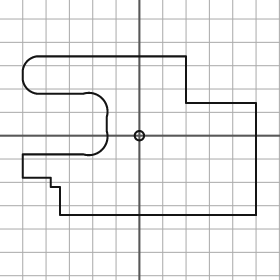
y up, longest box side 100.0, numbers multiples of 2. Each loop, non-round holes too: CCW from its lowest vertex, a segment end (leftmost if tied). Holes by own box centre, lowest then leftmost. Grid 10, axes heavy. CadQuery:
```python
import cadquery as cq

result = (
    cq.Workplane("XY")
    .moveTo(-34.0, -34.0)
    .lineTo(50.0, -34.0)
    .lineTo(50.0, 14.0)
    .lineTo(20.0, 14.0)
    .lineTo(20.0, 34.0)
    .lineTo(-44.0, 34.0)
    .threePointArc((-48.0, 32.0), (-50.0, 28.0))
    .lineTo(-50.0, 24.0)
    .threePointArc((-48.0, 20.0), (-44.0, 18.0))
    .lineTo(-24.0, 18.0)
    .threePointArc((-16.0, 16.0), (-14.0, 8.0))
    .lineTo(-14.0, 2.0)
    .threePointArc((-16.0, -6.0), (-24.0, -8.0))
    .lineTo(-50.0, -8.0)
    .lineTo(-50.0, -18.0)
    .lineTo(-38.0, -18.0)
    .lineTo(-38.0, -22.0)
    .lineTo(-34.0, -22.0)
    .close()
    .moveTo(0.0, 0.0)
    .circle(2.0)
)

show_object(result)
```